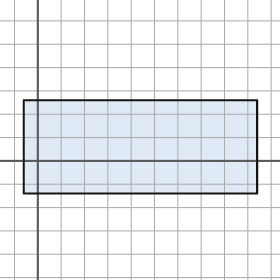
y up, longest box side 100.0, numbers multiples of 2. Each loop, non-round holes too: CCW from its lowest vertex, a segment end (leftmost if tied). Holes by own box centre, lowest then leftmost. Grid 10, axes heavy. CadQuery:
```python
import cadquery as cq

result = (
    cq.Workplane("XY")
    .moveTo(-6.0, -14.0)
    .lineTo(94.0, -14.0)
    .lineTo(94.0, 26.0)
    .lineTo(-6.0, 26.0)
    .close()
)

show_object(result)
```